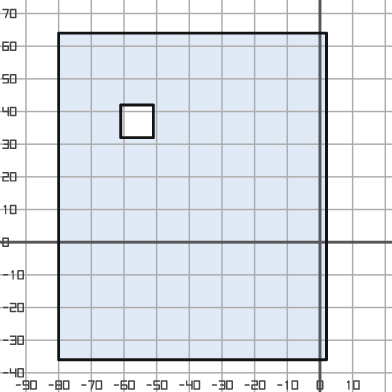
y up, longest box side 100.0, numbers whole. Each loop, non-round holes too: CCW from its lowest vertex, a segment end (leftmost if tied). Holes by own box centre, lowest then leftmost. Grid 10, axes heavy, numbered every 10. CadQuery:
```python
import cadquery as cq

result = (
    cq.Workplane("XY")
    .moveTo(-80.0, -36.0)
    .lineTo(2.0, -36.0)
    .lineTo(2.0, 64.0)
    .lineTo(-80.0, 64.0)
    .close()
    .moveTo(-61.0, 32.0)
    .lineTo(-51.0, 32.0)
    .lineTo(-51.0, 42.0)
    .lineTo(-61.0, 42.0)
    .close()
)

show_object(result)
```